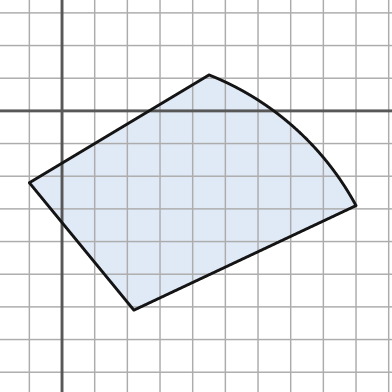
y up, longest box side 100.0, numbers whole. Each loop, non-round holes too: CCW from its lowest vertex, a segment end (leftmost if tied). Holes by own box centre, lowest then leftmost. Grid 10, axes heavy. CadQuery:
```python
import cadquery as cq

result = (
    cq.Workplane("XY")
    .moveTo(22.0, -61.0)
    .lineTo(90.0, -29.0)
    .threePointArc((71.0, -5.0), (45.0, 11.0))
    .lineTo(-10.0, -22.0)
    .close()
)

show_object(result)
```